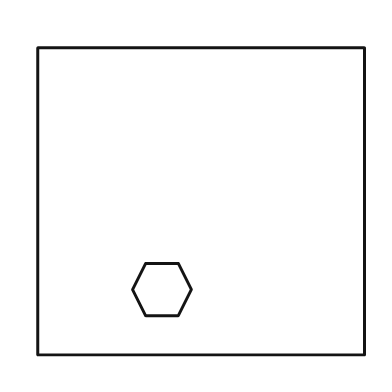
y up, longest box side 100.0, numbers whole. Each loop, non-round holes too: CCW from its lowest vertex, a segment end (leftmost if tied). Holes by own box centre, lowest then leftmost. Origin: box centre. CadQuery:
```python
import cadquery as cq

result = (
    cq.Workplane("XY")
    .moveTo(-50.0, -47.0)
    .lineTo(50.0, -47.0)
    .lineTo(50.0, 47.0)
    .lineTo(-50.0, 47.0)
    .close()
    .moveTo(-17.0, -35.0)
    .lineTo(-7.0, -35.0)
    .lineTo(-3.0, -27.0)
    .lineTo(-7.0, -19.0)
    .lineTo(-17.0, -19.0)
    .lineTo(-21.0, -27.0)
    .close()
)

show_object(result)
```